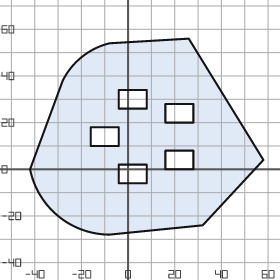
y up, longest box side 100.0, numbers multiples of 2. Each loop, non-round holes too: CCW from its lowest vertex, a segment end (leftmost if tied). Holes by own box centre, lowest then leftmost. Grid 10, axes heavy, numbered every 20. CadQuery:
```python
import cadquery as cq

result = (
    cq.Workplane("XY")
    .moveTo(-8.0, -28.0)
    .lineTo(32.0, -24.0)
    .lineTo(58.0, 4.0)
    .lineTo(26.0, 56.0)
    .lineTo(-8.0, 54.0)
    .threePointArc((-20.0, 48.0), (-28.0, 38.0))
    .lineTo(-42.0, 0.0)
    .threePointArc((-30.0, -20.0), (-8.0, -28.0))
    .close()
    .moveTo(-4.0, -6.0)
    .lineTo(8.0, -6.0)
    .lineTo(8.0, 2.0)
    .lineTo(-4.0, 2.0)
    .close()
    .moveTo(16.0, 0.0)
    .lineTo(28.0, 0.0)
    .lineTo(28.0, 8.0)
    .lineTo(16.0, 8.0)
    .close()
    .moveTo(-16.0, 10.0)
    .lineTo(-4.0, 10.0)
    .lineTo(-4.0, 18.0)
    .lineTo(-16.0, 18.0)
    .close()
    .moveTo(16.0, 20.0)
    .lineTo(28.0, 20.0)
    .lineTo(28.0, 28.0)
    .lineTo(16.0, 28.0)
    .close()
    .moveTo(-4.0, 26.0)
    .lineTo(8.0, 26.0)
    .lineTo(8.0, 34.0)
    .lineTo(-4.0, 34.0)
    .close()
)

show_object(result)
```